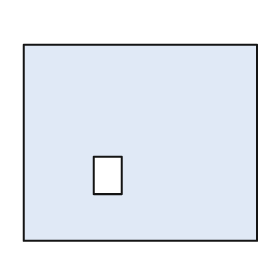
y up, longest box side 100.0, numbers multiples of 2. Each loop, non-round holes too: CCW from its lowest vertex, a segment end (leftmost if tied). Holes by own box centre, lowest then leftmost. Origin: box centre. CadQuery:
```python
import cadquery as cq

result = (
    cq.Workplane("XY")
    .moveTo(-50.0, -42.0)
    .lineTo(50.0, -42.0)
    .lineTo(50.0, 42.0)
    .lineTo(-50.0, 42.0)
    .close()
    .moveTo(-20.0, -22.0)
    .lineTo(-8.0, -22.0)
    .lineTo(-8.0, -6.0)
    .lineTo(-20.0, -6.0)
    .close()
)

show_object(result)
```